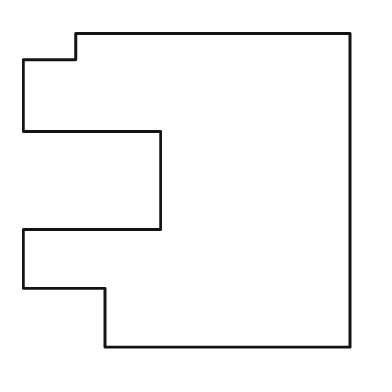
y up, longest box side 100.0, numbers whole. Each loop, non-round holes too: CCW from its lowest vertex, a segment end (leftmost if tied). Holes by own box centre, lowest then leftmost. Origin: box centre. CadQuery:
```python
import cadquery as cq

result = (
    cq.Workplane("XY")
    .moveTo(-25.0, -48.0)
    .lineTo(50.0, -48.0)
    .lineTo(50.0, 48.0)
    .lineTo(-34.0, 48.0)
    .lineTo(-34.0, 40.0)
    .lineTo(-50.0, 40.0)
    .lineTo(-50.0, 18.0)
    .lineTo(-8.0, 18.0)
    .lineTo(-8.0, -12.0)
    .lineTo(-50.0, -12.0)
    .lineTo(-50.0, -30.0)
    .lineTo(-25.0, -30.0)
    .close()
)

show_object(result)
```